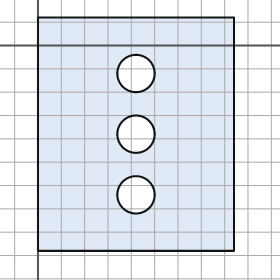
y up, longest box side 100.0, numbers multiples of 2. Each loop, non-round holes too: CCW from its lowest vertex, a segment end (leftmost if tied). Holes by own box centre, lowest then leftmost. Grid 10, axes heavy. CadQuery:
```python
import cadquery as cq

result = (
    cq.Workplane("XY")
    .moveTo(0.0, -88.0)
    .lineTo(84.0, -88.0)
    .lineTo(84.0, 12.0)
    .lineTo(0.0, 12.0)
    .close()
    .moveTo(42.0, -64.0)
    .circle(8.0)
    .moveTo(42.0, -38.0)
    .circle(8.0)
    .moveTo(42.0, -12.0)
    .circle(8.0)
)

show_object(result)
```